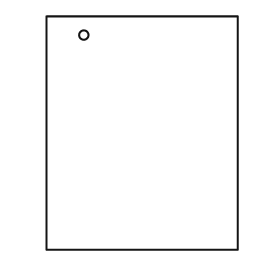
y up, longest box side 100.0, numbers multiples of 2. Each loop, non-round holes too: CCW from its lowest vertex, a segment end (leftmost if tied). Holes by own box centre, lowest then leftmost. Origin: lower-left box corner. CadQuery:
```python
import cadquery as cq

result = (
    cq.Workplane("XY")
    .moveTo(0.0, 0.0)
    .lineTo(82.0, 0.0)
    .lineTo(82.0, 100.0)
    .lineTo(0.0, 100.0)
    .close()
    .moveTo(16.0, 92.0)
    .circle(2.0)
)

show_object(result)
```